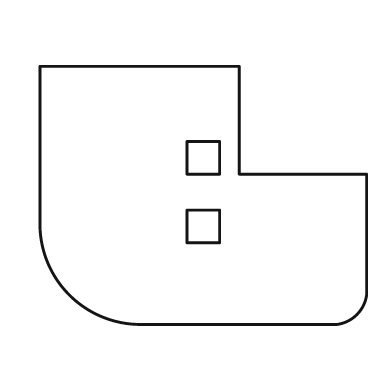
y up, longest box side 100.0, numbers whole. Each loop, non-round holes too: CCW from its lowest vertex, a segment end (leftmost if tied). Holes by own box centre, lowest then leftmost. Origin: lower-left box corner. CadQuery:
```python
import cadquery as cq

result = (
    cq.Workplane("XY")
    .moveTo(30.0, 0.0)
    .lineTo(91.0, 0.0)
    .threePointArc((97.0, 3.0), (100.0, 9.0))
    .lineTo(100.0, 46.0)
    .lineTo(61.0, 46.0)
    .lineTo(61.0, 79.0)
    .lineTo(0.0, 79.0)
    .lineTo(0.0, 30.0)
    .threePointArc((9.0, 9.0), (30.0, 0.0))
    .close()
    .moveTo(45.0, 25.0)
    .lineTo(55.0, 25.0)
    .lineTo(55.0, 35.0)
    .lineTo(45.0, 35.0)
    .close()
    .moveTo(45.0, 46.0)
    .lineTo(55.0, 46.0)
    .lineTo(55.0, 56.0)
    .lineTo(45.0, 56.0)
    .close()
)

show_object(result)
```